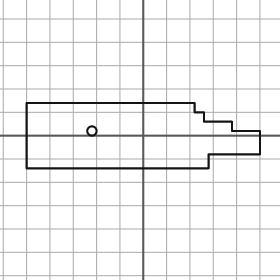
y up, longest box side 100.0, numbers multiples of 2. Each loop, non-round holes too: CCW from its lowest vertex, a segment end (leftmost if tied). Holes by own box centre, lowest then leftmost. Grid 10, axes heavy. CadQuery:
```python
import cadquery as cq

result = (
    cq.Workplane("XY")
    .moveTo(-50.0, -14.0)
    .lineTo(28.0, -14.0)
    .lineTo(28.0, -8.0)
    .lineTo(50.0, -8.0)
    .lineTo(50.0, 2.0)
    .lineTo(38.0, 2.0)
    .lineTo(38.0, 6.0)
    .lineTo(26.0, 6.0)
    .lineTo(26.0, 10.0)
    .lineTo(22.0, 10.0)
    .lineTo(22.0, 14.0)
    .lineTo(-50.0, 14.0)
    .close()
    .moveTo(-22.0, 2.0)
    .circle(2.0)
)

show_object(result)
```